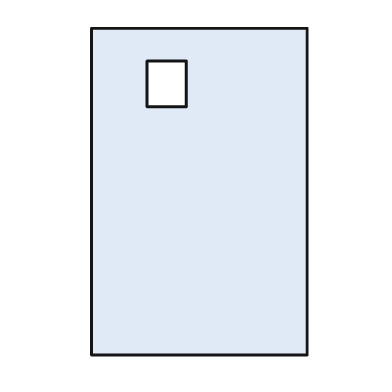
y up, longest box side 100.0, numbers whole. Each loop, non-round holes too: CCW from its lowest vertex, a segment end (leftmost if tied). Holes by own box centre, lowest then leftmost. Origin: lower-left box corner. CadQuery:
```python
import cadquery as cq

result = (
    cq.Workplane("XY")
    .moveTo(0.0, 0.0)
    .lineTo(66.0, 0.0)
    .lineTo(66.0, 100.0)
    .lineTo(0.0, 100.0)
    .close()
    .moveTo(17.0, 76.0)
    .lineTo(29.0, 76.0)
    .lineTo(29.0, 90.0)
    .lineTo(17.0, 90.0)
    .close()
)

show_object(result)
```